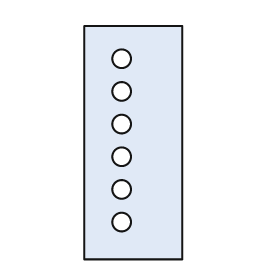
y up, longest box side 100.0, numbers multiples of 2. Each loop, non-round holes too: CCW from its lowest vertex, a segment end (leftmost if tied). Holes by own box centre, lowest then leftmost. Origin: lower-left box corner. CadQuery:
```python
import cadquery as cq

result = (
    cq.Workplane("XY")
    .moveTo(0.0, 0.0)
    .lineTo(42.0, 0.0)
    .lineTo(42.0, 100.0)
    .lineTo(0.0, 100.0)
    .close()
    .moveTo(16.0, 16.0)
    .circle(4.0)
    .moveTo(16.0, 30.0)
    .circle(4.0)
    .moveTo(16.0, 44.0)
    .circle(4.0)
    .moveTo(16.0, 58.0)
    .circle(4.0)
    .moveTo(16.0, 72.0)
    .circle(4.0)
    .moveTo(16.0, 86.0)
    .circle(4.0)
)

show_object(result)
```